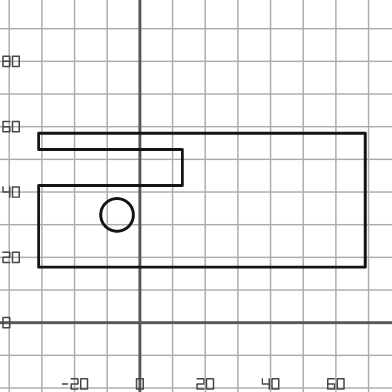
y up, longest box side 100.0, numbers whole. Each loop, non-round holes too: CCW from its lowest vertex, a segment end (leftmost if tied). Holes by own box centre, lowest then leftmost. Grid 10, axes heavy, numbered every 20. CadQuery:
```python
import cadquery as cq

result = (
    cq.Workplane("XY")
    .moveTo(-31.0, 17.0)
    .lineTo(69.0, 17.0)
    .lineTo(69.0, 58.0)
    .lineTo(-31.0, 58.0)
    .lineTo(-31.0, 53.0)
    .lineTo(13.0, 53.0)
    .lineTo(13.0, 42.0)
    .lineTo(-31.0, 42.0)
    .close()
    .moveTo(-7.0, 33.0)
    .circle(5.0)
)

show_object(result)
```